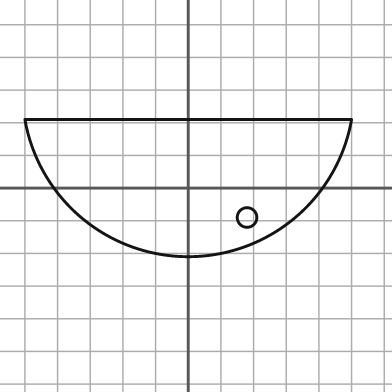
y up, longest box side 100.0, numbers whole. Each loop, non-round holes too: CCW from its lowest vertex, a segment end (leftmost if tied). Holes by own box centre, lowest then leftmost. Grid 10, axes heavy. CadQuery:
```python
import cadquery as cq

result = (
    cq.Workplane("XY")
    .moveTo(-50.0, 21.0)
    .threePointArc((0.0, -21.0), (50.0, 21.0))
    .close()
    .moveTo(18.0, -9.0)
    .circle(3.0)
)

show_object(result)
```